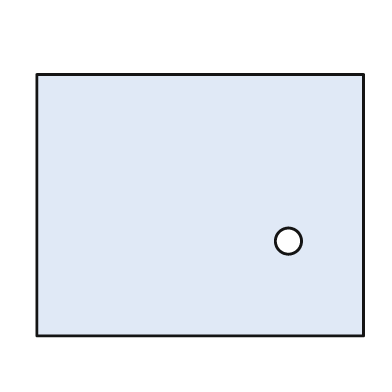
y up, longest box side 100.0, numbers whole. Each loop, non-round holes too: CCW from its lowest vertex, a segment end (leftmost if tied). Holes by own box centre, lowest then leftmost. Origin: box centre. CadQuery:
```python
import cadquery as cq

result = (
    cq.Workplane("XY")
    .moveTo(-50.0, -40.0)
    .lineTo(50.0, -40.0)
    .lineTo(50.0, 40.0)
    .lineTo(-50.0, 40.0)
    .close()
    .moveTo(27.0, -11.0)
    .circle(4.0)
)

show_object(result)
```